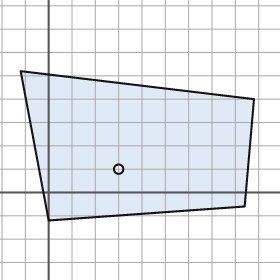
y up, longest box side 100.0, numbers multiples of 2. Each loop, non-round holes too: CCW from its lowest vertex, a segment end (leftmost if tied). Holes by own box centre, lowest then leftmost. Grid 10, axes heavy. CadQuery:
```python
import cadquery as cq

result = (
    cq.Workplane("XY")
    .moveTo(0.0, -12.0)
    .lineTo(84.0, -6.0)
    .lineTo(88.0, 40.0)
    .lineTo(-12.0, 52.0)
    .close()
    .moveTo(30.0, 10.0)
    .circle(2.0)
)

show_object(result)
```